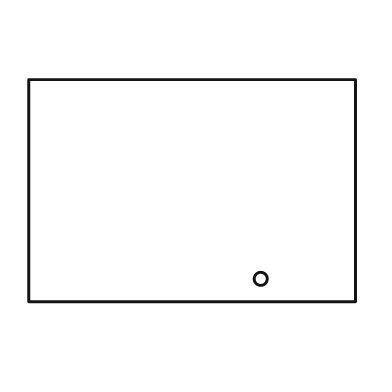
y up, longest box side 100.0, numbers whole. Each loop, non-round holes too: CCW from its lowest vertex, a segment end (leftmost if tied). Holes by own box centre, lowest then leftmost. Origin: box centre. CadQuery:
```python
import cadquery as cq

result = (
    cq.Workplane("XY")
    .moveTo(-50.0, -34.0)
    .lineTo(50.0, -34.0)
    .lineTo(50.0, 34.0)
    .lineTo(-50.0, 34.0)
    .close()
    .moveTo(21.0, -27.0)
    .circle(2.0)
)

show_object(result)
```